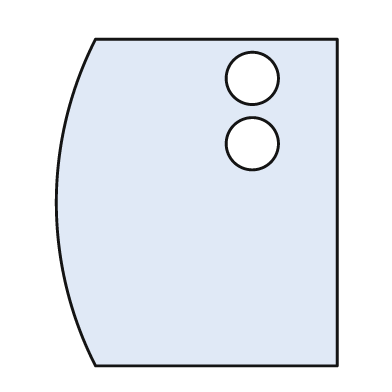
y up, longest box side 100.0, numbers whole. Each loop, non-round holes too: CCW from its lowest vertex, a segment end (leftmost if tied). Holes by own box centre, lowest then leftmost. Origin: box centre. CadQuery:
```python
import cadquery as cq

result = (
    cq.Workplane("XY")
    .moveTo(-31.0, -50.0)
    .lineTo(43.0, -50.0)
    .lineTo(43.0, 50.0)
    .lineTo(-31.0, 50.0)
    .threePointArc((-43.0, 0.0), (-31.0, -50.0))
    .close()
    .moveTo(17.0, 18.0)
    .circle(8.0)
    .moveTo(17.0, 38.0)
    .circle(8.0)
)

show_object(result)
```